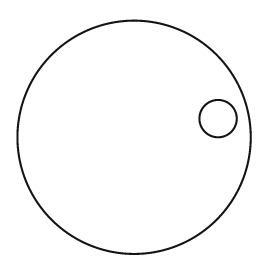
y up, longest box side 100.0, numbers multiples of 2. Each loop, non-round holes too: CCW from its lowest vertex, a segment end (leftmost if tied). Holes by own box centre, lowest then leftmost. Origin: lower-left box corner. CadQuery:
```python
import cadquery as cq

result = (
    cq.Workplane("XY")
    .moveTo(50.0, 50.0)
    .circle(50.0)
    .moveTo(86.0, 58.0)
    .circle(8.0)
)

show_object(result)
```